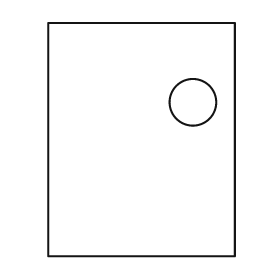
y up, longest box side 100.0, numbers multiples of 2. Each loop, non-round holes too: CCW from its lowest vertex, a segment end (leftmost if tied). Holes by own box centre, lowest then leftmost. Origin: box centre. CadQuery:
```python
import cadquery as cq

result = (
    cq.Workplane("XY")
    .moveTo(-40.0, -50.0)
    .lineTo(40.0, -50.0)
    .lineTo(40.0, 50.0)
    .lineTo(-40.0, 50.0)
    .close()
    .moveTo(22.0, 16.0)
    .circle(10.0)
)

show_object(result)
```